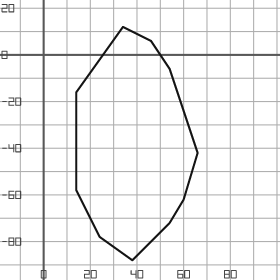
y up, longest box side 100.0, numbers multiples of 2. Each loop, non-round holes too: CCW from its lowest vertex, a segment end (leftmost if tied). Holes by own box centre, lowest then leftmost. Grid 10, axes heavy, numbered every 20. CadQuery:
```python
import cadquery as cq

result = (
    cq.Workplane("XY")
    .moveTo(38.0, -88.0)
    .lineTo(54.0, -72.0)
    .lineTo(60.0, -62.0)
    .lineTo(66.0, -42.0)
    .lineTo(54.0, -6.0)
    .lineTo(46.0, 6.0)
    .lineTo(34.0, 12.0)
    .lineTo(14.0, -16.0)
    .lineTo(14.0, -58.0)
    .lineTo(24.0, -78.0)
    .close()
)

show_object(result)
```